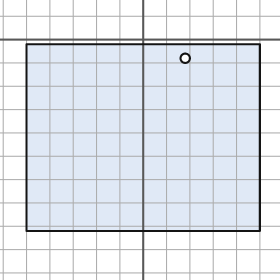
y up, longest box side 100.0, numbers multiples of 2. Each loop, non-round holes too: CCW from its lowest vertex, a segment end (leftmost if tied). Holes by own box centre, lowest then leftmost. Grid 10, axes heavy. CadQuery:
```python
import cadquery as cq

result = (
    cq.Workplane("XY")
    .moveTo(-50.0, -82.0)
    .lineTo(50.0, -82.0)
    .lineTo(50.0, -2.0)
    .lineTo(-50.0, -2.0)
    .close()
    .moveTo(18.0, -8.0)
    .circle(2.0)
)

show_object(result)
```